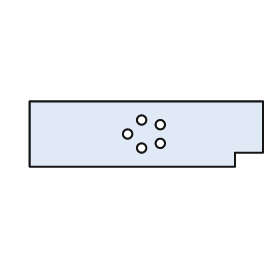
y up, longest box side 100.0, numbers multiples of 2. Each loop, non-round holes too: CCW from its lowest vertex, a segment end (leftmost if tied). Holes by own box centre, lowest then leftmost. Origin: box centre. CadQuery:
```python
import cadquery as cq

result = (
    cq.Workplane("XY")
    .moveTo(-50.0, -14.0)
    .lineTo(38.0, -14.0)
    .lineTo(38.0, -8.0)
    .lineTo(50.0, -8.0)
    .lineTo(50.0, 14.0)
    .lineTo(-50.0, 14.0)
    .close()
    .moveTo(-2.0, -6.0)
    .circle(2.0)
    .moveTo(6.0, -4.0)
    .circle(2.0)
    .moveTo(-8.0, 0.0)
    .circle(2.0)
    .moveTo(6.0, 4.0)
    .circle(2.0)
    .moveTo(-2.0, 6.0)
    .circle(2.0)
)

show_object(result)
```